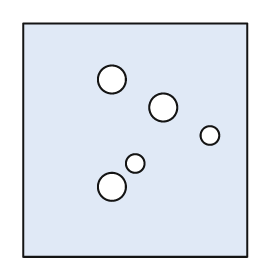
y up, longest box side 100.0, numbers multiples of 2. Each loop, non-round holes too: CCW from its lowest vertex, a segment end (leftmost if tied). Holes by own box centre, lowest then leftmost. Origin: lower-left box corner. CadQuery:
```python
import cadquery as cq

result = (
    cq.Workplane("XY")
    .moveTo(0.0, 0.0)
    .lineTo(96.0, 0.0)
    .lineTo(96.0, 100.0)
    .lineTo(0.0, 100.0)
    .close()
    .moveTo(38.0, 30.0)
    .circle(6.0)
    .moveTo(48.0, 40.0)
    .circle(4.0)
    .moveTo(80.0, 52.0)
    .circle(4.0)
    .moveTo(60.0, 64.0)
    .circle(6.0)
    .moveTo(38.0, 76.0)
    .circle(6.0)
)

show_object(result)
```